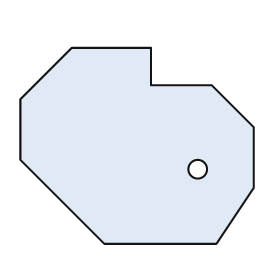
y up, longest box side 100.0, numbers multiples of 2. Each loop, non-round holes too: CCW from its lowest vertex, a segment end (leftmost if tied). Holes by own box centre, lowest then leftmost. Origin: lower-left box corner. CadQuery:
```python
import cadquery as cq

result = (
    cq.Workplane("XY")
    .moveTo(36.0, 0.0)
    .lineTo(84.0, 0.0)
    .lineTo(100.0, 24.0)
    .lineTo(100.0, 50.0)
    .lineTo(82.0, 68.0)
    .lineTo(56.0, 68.0)
    .lineTo(56.0, 84.0)
    .lineTo(22.0, 84.0)
    .lineTo(0.0, 62.0)
    .lineTo(0.0, 36.0)
    .close()
    .moveTo(76.0, 32.0)
    .circle(4.0)
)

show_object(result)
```